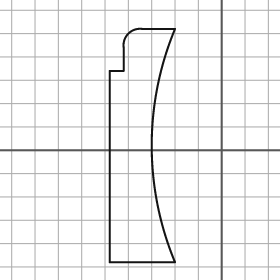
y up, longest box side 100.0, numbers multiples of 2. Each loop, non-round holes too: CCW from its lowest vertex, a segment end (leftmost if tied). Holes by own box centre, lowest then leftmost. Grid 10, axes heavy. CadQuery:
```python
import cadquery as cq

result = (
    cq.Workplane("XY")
    .moveTo(-48.0, -48.0)
    .lineTo(-20.0, -48.0)
    .threePointArc((-30.0, 2.0), (-20.0, 52.0))
    .lineTo(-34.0, 52.0)
    .threePointArc((-40.0, 50.0), (-42.0, 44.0))
    .lineTo(-42.0, 34.0)
    .lineTo(-48.0, 34.0)
    .close()
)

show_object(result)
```